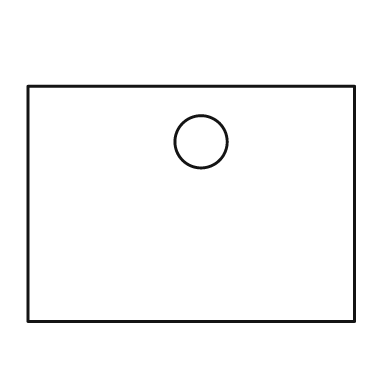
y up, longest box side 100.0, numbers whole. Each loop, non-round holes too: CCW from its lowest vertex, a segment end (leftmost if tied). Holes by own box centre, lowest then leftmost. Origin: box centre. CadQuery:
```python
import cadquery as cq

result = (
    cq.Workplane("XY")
    .moveTo(-50.0, -36.0)
    .lineTo(50.0, -36.0)
    .lineTo(50.0, 36.0)
    .lineTo(-50.0, 36.0)
    .close()
    .moveTo(3.0, 19.0)
    .circle(8.0)
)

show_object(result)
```